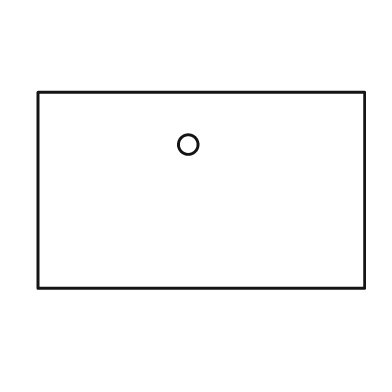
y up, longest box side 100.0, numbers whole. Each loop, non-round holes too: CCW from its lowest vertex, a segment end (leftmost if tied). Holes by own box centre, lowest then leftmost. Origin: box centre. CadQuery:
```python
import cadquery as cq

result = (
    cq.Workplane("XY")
    .moveTo(-50.0, -30.0)
    .lineTo(50.0, -30.0)
    .lineTo(50.0, 30.0)
    .lineTo(-50.0, 30.0)
    .close()
    .moveTo(-4.0, 14.0)
    .circle(3.0)
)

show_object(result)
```